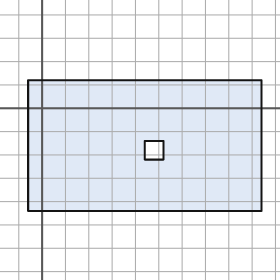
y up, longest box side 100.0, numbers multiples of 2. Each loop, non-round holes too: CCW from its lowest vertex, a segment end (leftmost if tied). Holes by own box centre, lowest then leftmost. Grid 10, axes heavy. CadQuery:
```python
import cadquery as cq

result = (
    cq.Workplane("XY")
    .moveTo(-6.0, -44.0)
    .lineTo(94.0, -44.0)
    .lineTo(94.0, 12.0)
    .lineTo(-6.0, 12.0)
    .close()
    .moveTo(44.0, -22.0)
    .lineTo(52.0, -22.0)
    .lineTo(52.0, -14.0)
    .lineTo(44.0, -14.0)
    .close()
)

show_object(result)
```